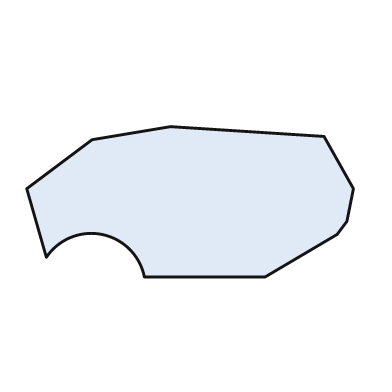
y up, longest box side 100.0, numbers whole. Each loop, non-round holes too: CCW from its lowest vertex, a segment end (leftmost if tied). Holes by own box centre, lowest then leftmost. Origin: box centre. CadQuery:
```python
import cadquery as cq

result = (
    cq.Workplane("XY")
    .moveTo(-14.0, -23.0)
    .lineTo(23.0, -23.0)
    .lineTo(45.0, -10.0)
    .lineTo(48.0, -6.0)
    .lineTo(50.0, 4.0)
    .lineTo(41.0, 20.0)
    .lineTo(-6.0, 23.0)
    .lineTo(-30.0, 19.0)
    .lineTo(-50.0, 4.0)
    .lineTo(-44.0, -17.0)
    .threePointArc((-27.0, -10.0), (-14.0, -23.0))
    .close()
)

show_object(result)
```